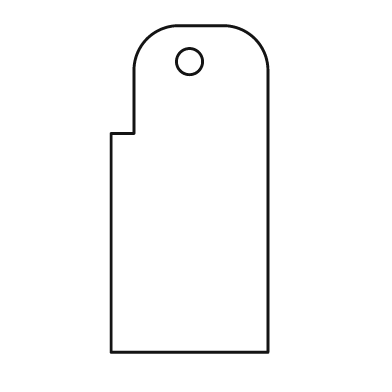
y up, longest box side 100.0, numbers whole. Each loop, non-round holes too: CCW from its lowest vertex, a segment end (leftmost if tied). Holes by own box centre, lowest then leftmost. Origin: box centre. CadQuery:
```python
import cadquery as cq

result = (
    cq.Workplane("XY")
    .moveTo(-24.0, -50.0)
    .lineTo(24.0, -50.0)
    .lineTo(24.0, 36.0)
    .threePointArc((20.0, 46.0), (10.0, 50.0))
    .lineTo(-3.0, 50.0)
    .threePointArc((-13.0, 46.0), (-17.0, 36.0))
    .lineTo(-17.0, 17.0)
    .lineTo(-24.0, 17.0)
    .close()
    .moveTo(0.0, 39.0)
    .circle(4.0)
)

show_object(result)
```